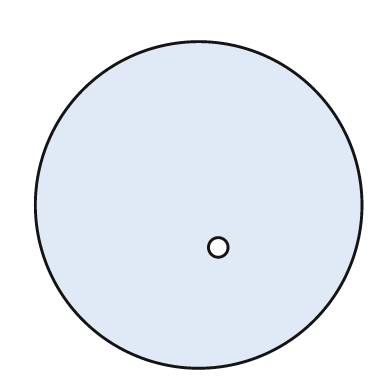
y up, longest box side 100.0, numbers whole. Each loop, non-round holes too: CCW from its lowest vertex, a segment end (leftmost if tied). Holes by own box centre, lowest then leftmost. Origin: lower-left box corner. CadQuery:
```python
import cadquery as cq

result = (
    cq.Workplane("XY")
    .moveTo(50.0, 50.0)
    .circle(50.0)
    .moveTo(56.0, 37.0)
    .circle(3.0)
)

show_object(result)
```